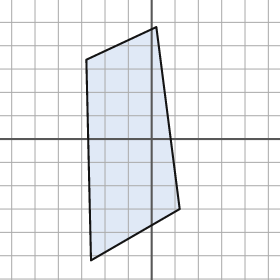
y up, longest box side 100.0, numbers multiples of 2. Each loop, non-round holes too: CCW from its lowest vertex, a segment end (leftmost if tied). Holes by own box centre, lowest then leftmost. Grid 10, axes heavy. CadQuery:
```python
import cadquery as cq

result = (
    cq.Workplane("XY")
    .moveTo(-26.0, -52.0)
    .lineTo(12.0, -30.0)
    .lineTo(2.0, 48.0)
    .lineTo(-28.0, 34.0)
    .close()
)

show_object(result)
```